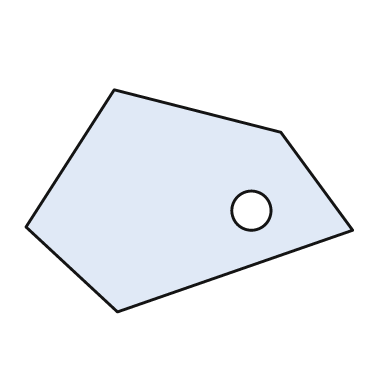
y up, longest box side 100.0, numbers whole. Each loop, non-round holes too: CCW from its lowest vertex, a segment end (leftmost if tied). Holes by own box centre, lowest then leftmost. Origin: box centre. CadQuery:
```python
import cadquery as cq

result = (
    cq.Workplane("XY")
    .moveTo(-22.0, -34.0)
    .lineTo(50.0, -9.0)
    .lineTo(28.0, 21.0)
    .lineTo(-23.0, 34.0)
    .lineTo(-50.0, -8.0)
    .close()
    .moveTo(19.0, -3.0)
    .circle(6.0)
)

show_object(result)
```